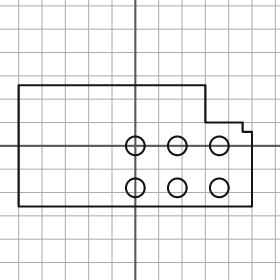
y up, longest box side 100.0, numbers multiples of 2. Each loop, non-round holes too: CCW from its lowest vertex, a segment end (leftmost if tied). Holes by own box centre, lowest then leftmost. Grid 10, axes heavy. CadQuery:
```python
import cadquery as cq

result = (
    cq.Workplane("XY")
    .moveTo(-50.0, -26.0)
    .lineTo(50.0, -26.0)
    .lineTo(50.0, 6.0)
    .lineTo(46.0, 6.0)
    .lineTo(46.0, 10.0)
    .lineTo(30.0, 10.0)
    .lineTo(30.0, 26.0)
    .lineTo(-50.0, 26.0)
    .close()
    .moveTo(0.0, -18.0)
    .circle(4.0)
    .moveTo(18.0, -18.0)
    .circle(4.0)
    .moveTo(36.0, -18.0)
    .circle(4.0)
    .moveTo(0.0, 0.0)
    .circle(4.0)
    .moveTo(18.0, 0.0)
    .circle(4.0)
    .moveTo(36.0, 0.0)
    .circle(4.0)
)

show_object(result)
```